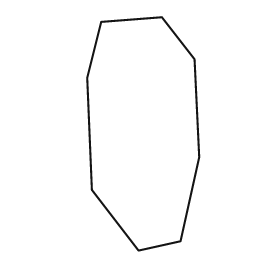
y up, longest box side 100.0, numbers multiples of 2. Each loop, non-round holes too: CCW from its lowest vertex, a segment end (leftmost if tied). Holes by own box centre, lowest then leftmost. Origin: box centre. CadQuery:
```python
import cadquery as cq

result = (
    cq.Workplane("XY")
    .moveTo(-2.0, -50.0)
    .lineTo(16.0, -46.0)
    .lineTo(24.0, -10.0)
    .lineTo(22.0, 32.0)
    .lineTo(8.0, 50.0)
    .lineTo(-18.0, 48.0)
    .lineTo(-24.0, 24.0)
    .lineTo(-22.0, -24.0)
    .close()
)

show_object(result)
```